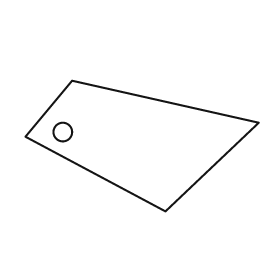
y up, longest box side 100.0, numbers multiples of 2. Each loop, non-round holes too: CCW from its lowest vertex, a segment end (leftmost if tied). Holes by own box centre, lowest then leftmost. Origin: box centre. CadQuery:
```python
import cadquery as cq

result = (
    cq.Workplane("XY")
    .moveTo(10.0, -28.0)
    .lineTo(50.0, 10.0)
    .lineTo(-30.0, 28.0)
    .lineTo(-50.0, 4.0)
    .close()
    .moveTo(-34.0, 6.0)
    .circle(4.0)
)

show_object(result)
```